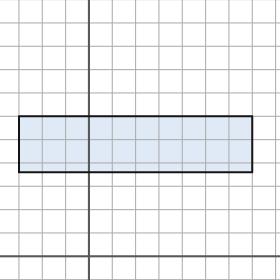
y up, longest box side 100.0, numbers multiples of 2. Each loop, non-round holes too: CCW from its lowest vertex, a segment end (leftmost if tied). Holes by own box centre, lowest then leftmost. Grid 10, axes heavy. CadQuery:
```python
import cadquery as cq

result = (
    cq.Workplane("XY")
    .moveTo(-30.0, 36.0)
    .lineTo(70.0, 36.0)
    .lineTo(70.0, 60.0)
    .lineTo(-30.0, 60.0)
    .close()
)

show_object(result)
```